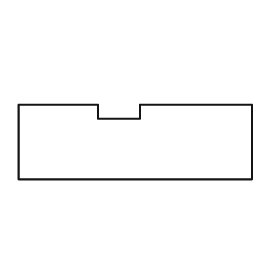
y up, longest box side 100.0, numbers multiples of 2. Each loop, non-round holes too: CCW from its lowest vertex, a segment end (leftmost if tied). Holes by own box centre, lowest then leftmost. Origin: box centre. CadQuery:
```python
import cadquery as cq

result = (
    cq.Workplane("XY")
    .moveTo(-50.0, -16.0)
    .lineTo(50.0, -16.0)
    .lineTo(50.0, 16.0)
    .lineTo(2.0, 16.0)
    .lineTo(2.0, 10.0)
    .lineTo(-16.0, 10.0)
    .lineTo(-16.0, 16.0)
    .lineTo(-50.0, 16.0)
    .close()
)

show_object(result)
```